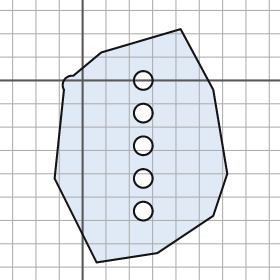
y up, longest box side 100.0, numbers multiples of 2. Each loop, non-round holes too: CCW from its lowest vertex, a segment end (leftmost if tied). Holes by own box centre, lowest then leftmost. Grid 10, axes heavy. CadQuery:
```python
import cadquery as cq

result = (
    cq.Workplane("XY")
    .moveTo(6.0, -78.0)
    .lineTo(32.0, -74.0)
    .lineTo(56.0, -58.0)
    .lineTo(62.0, -40.0)
    .lineTo(56.0, -4.0)
    .lineTo(42.0, 22.0)
    .lineTo(8.0, 12.0)
    .lineTo(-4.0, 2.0)
    .threePointArc((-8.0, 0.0), (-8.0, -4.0))
    .lineTo(-12.0, -42.0)
    .close()
    .moveTo(26.0, -56.0)
    .circle(4.0)
    .moveTo(26.0, -42.0)
    .circle(4.0)
    .moveTo(26.0, -28.0)
    .circle(4.0)
    .moveTo(26.0, -14.0)
    .circle(4.0)
    .moveTo(26.0, 0.0)
    .circle(4.0)
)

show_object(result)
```